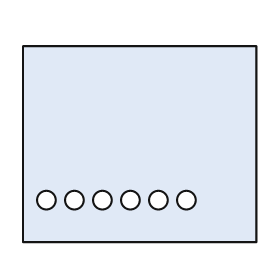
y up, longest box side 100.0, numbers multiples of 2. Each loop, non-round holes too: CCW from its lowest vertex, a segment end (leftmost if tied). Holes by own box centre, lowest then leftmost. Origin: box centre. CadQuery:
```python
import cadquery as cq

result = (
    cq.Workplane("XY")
    .moveTo(-50.0, -42.0)
    .lineTo(50.0, -42.0)
    .lineTo(50.0, 42.0)
    .lineTo(-50.0, 42.0)
    .close()
    .moveTo(-40.0, -24.0)
    .circle(4.0)
    .moveTo(-28.0, -24.0)
    .circle(4.0)
    .moveTo(-16.0, -24.0)
    .circle(4.0)
    .moveTo(-4.0, -24.0)
    .circle(4.0)
    .moveTo(8.0, -24.0)
    .circle(4.0)
    .moveTo(20.0, -24.0)
    .circle(4.0)
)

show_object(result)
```